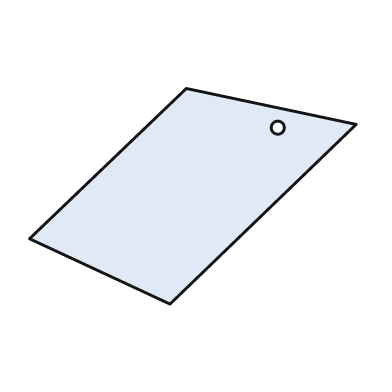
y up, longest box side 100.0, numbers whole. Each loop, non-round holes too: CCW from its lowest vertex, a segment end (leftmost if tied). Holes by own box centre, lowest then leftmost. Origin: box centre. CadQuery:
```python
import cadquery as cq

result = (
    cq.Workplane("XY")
    .moveTo(-7.0, -33.0)
    .lineTo(50.0, 22.0)
    .lineTo(-2.0, 33.0)
    .lineTo(-50.0, -13.0)
    .close()
    .moveTo(26.0, 21.0)
    .circle(2.0)
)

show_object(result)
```